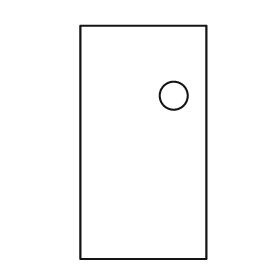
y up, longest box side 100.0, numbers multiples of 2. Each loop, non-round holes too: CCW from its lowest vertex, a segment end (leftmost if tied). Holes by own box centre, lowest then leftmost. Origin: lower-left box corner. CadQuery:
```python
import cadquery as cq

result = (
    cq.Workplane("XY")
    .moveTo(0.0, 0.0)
    .lineTo(54.0, 0.0)
    .lineTo(54.0, 100.0)
    .lineTo(0.0, 100.0)
    .close()
    .moveTo(40.0, 70.0)
    .circle(6.0)
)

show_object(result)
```